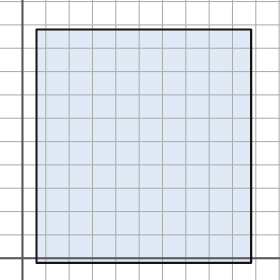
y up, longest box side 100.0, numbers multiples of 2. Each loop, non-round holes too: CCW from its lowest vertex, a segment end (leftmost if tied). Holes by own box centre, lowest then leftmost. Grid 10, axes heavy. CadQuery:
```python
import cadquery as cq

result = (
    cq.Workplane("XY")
    .moveTo(6.0, -2.0)
    .lineTo(98.0, -2.0)
    .lineTo(98.0, 98.0)
    .lineTo(6.0, 98.0)
    .close()
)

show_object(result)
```